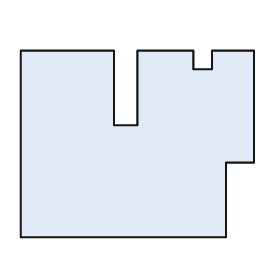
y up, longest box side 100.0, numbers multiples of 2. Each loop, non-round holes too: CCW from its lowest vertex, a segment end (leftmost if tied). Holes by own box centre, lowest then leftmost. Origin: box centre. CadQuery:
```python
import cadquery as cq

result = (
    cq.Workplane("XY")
    .moveTo(-50.0, -40.0)
    .lineTo(38.0, -40.0)
    .lineTo(38.0, -8.0)
    .lineTo(50.0, -8.0)
    .lineTo(50.0, 40.0)
    .lineTo(32.0, 40.0)
    .lineTo(32.0, 32.0)
    .lineTo(24.0, 32.0)
    .lineTo(24.0, 40.0)
    .lineTo(0.0, 40.0)
    .lineTo(0.0, 8.0)
    .lineTo(-10.0, 8.0)
    .lineTo(-10.0, 40.0)
    .lineTo(-50.0, 40.0)
    .close()
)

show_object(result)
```